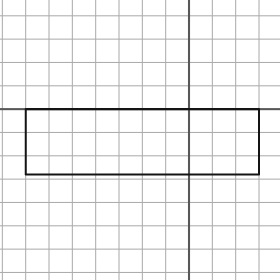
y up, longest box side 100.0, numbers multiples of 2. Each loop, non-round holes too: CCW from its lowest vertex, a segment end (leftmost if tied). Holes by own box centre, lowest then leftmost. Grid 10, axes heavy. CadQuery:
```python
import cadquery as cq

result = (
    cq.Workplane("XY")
    .moveTo(-70.0, -28.0)
    .lineTo(30.0, -28.0)
    .lineTo(30.0, 0.0)
    .lineTo(-70.0, 0.0)
    .close()
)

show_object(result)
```